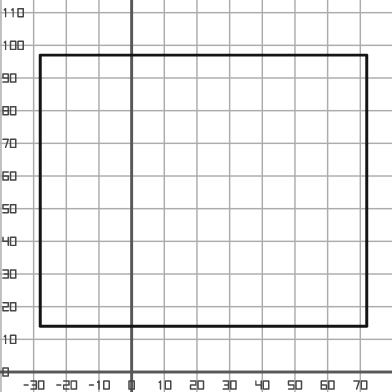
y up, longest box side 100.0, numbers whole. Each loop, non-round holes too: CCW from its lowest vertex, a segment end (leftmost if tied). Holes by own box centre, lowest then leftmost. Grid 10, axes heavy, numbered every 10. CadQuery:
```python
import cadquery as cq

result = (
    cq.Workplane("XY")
    .moveTo(-28.0, 14.0)
    .lineTo(72.0, 14.0)
    .lineTo(72.0, 97.0)
    .lineTo(-28.0, 97.0)
    .close()
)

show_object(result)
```